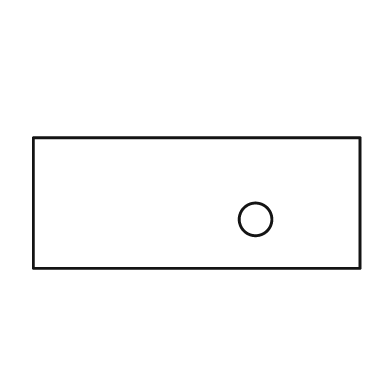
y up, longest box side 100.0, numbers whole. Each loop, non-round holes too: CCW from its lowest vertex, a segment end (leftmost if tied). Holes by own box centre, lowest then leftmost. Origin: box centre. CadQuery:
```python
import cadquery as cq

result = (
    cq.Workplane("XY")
    .moveTo(-50.0, -20.0)
    .lineTo(50.0, -20.0)
    .lineTo(50.0, 20.0)
    .lineTo(-50.0, 20.0)
    .close()
    .moveTo(18.0, -5.0)
    .circle(5.0)
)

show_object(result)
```